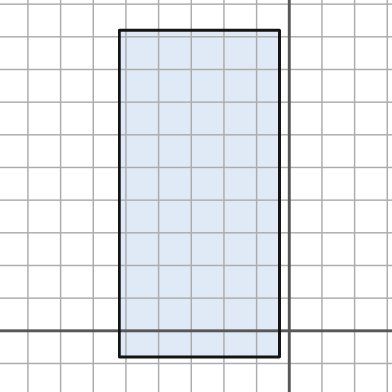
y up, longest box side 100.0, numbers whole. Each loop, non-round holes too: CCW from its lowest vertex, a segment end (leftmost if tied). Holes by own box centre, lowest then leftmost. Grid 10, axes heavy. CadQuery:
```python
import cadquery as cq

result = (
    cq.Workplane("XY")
    .moveTo(-52.0, -8.0)
    .lineTo(-3.0, -8.0)
    .lineTo(-3.0, 92.0)
    .lineTo(-52.0, 92.0)
    .close()
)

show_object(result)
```